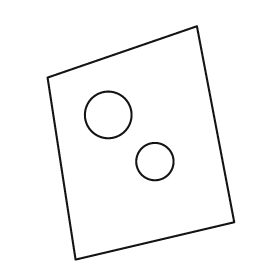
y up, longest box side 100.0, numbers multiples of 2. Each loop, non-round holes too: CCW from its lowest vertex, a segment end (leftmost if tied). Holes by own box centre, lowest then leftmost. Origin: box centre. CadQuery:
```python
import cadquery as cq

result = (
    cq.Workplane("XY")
    .moveTo(-28.0, -50.0)
    .lineTo(40.0, -34.0)
    .lineTo(24.0, 50.0)
    .lineTo(-40.0, 28.0)
    .close()
    .moveTo(6.0, -8.0)
    .circle(8.0)
    .moveTo(-14.0, 12.0)
    .circle(10.0)
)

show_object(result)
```